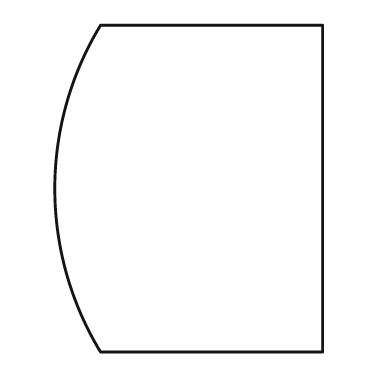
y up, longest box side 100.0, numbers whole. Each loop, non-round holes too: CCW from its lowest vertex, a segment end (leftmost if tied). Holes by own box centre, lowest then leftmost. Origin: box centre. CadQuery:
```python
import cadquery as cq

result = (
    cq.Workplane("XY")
    .moveTo(-27.0, -50.0)
    .lineTo(41.0, -50.0)
    .lineTo(41.0, 50.0)
    .lineTo(-27.0, 50.0)
    .threePointArc((-41.0, 0.0), (-27.0, -50.0))
    .close()
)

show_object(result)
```